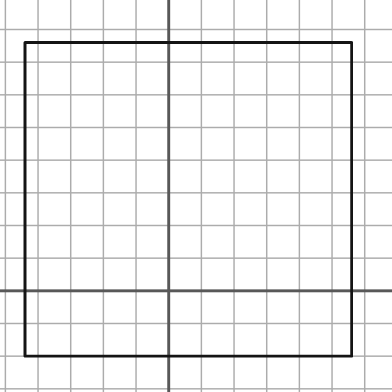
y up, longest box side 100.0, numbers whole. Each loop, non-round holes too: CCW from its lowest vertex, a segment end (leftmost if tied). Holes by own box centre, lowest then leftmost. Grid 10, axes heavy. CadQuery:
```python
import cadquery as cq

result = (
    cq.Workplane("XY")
    .moveTo(-44.0, -20.0)
    .lineTo(56.0, -20.0)
    .lineTo(56.0, 76.0)
    .lineTo(-44.0, 76.0)
    .close()
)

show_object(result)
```